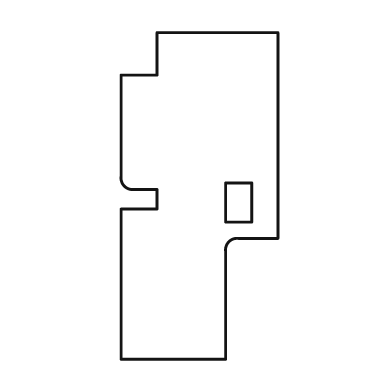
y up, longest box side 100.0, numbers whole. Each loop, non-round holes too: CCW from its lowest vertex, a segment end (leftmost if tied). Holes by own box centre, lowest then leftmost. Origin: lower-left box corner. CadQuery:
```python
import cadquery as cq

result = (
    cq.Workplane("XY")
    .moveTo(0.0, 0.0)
    .lineTo(32.0, 0.0)
    .lineTo(32.0, 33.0)
    .threePointArc((33.0, 36.0), (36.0, 37.0))
    .lineTo(48.0, 37.0)
    .lineTo(48.0, 100.0)
    .lineTo(11.0, 100.0)
    .lineTo(11.0, 87.0)
    .lineTo(0.0, 87.0)
    .lineTo(0.0, 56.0)
    .threePointArc((1.0, 53.0), (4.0, 52.0))
    .lineTo(11.0, 52.0)
    .lineTo(11.0, 46.0)
    .lineTo(0.0, 46.0)
    .close()
    .moveTo(32.0, 42.0)
    .lineTo(40.0, 42.0)
    .lineTo(40.0, 54.0)
    .lineTo(32.0, 54.0)
    .close()
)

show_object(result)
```